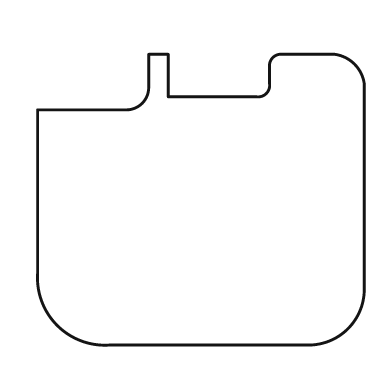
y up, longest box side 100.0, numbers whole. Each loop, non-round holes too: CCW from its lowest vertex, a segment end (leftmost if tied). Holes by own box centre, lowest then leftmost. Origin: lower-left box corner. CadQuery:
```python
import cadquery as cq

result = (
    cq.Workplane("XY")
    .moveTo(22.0, 0.0)
    .lineTo(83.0, 0.0)
    .threePointArc((95.0, 5.0), (100.0, 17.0))
    .lineTo(100.0, 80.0)
    .threePointArc((97.0, 86.0), (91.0, 89.0))
    .lineTo(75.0, 89.0)
    .threePointArc((72.0, 88.0), (71.0, 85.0))
    .lineTo(71.0, 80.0)
    .threePointArc((70.0, 77.0), (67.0, 76.0))
    .lineTo(40.0, 76.0)
    .lineTo(40.0, 89.0)
    .lineTo(34.0, 89.0)
    .lineTo(34.0, 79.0)
    .threePointArc((32.0, 74.0), (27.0, 72.0))
    .lineTo(0.0, 72.0)
    .lineTo(0.0, 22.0)
    .threePointArc((6.0, 6.0), (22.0, 0.0))
    .close()
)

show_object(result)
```